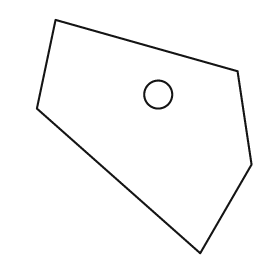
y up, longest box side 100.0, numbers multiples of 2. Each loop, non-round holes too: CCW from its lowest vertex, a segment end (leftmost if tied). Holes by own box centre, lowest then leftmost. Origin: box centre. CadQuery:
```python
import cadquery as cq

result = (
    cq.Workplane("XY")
    .moveTo(24.0, -50.0)
    .lineTo(46.0, -12.0)
    .lineTo(40.0, 28.0)
    .lineTo(-38.0, 50.0)
    .lineTo(-46.0, 12.0)
    .close()
    .moveTo(6.0, 18.0)
    .circle(6.0)
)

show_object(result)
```